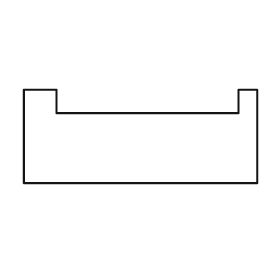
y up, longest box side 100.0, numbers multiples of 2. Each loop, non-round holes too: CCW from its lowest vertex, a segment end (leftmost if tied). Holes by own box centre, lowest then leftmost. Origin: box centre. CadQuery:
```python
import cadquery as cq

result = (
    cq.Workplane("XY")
    .moveTo(-50.0, -20.0)
    .lineTo(50.0, -20.0)
    .lineTo(50.0, 20.0)
    .lineTo(42.0, 20.0)
    .lineTo(42.0, 10.0)
    .lineTo(-36.0, 10.0)
    .lineTo(-36.0, 20.0)
    .lineTo(-50.0, 20.0)
    .close()
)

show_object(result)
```